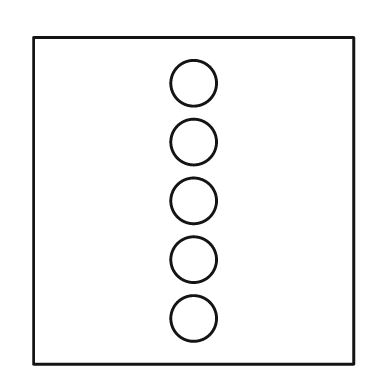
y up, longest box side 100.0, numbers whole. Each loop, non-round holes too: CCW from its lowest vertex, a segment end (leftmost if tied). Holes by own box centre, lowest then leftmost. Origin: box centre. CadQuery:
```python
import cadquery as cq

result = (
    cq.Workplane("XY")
    .moveTo(-49.0, -50.0)
    .lineTo(49.0, -50.0)
    .lineTo(49.0, 50.0)
    .lineTo(-49.0, 50.0)
    .close()
    .moveTo(0.0, -36.0)
    .circle(7.0)
    .moveTo(0.0, -18.0)
    .circle(7.0)
    .moveTo(0.0, 0.0)
    .circle(7.0)
    .moveTo(0.0, 18.0)
    .circle(7.0)
    .moveTo(0.0, 36.0)
    .circle(7.0)
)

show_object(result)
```